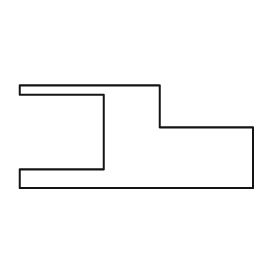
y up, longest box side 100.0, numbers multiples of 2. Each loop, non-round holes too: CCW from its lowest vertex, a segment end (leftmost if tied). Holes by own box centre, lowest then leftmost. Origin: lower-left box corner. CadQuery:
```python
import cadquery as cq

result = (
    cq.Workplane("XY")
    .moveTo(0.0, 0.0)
    .lineTo(100.0, 0.0)
    .lineTo(100.0, 26.0)
    .lineTo(60.0, 26.0)
    .lineTo(60.0, 44.0)
    .lineTo(0.0, 44.0)
    .lineTo(0.0, 40.0)
    .lineTo(36.0, 40.0)
    .lineTo(36.0, 8.0)
    .lineTo(0.0, 8.0)
    .close()
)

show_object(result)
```